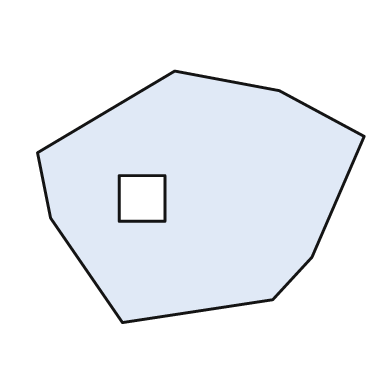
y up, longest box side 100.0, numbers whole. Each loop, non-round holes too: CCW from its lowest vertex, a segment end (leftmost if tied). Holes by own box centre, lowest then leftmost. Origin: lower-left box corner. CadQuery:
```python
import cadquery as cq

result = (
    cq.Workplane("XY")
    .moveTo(26.0, 0.0)
    .lineTo(72.0, 7.0)
    .lineTo(84.0, 20.0)
    .lineTo(100.0, 57.0)
    .lineTo(74.0, 71.0)
    .lineTo(42.0, 77.0)
    .lineTo(0.0, 52.0)
    .lineTo(4.0, 32.0)
    .close()
    .moveTo(25.0, 31.0)
    .lineTo(39.0, 31.0)
    .lineTo(39.0, 45.0)
    .lineTo(25.0, 45.0)
    .close()
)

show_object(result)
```